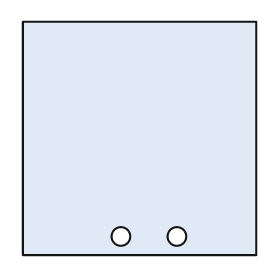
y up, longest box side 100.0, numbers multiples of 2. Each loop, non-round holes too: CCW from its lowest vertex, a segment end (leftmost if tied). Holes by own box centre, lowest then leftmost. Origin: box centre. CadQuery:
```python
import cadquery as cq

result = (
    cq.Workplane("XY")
    .moveTo(-50.0, -50.0)
    .lineTo(50.0, -50.0)
    .lineTo(50.0, 50.0)
    .lineTo(-50.0, 50.0)
    .close()
    .moveTo(-8.0, -42.0)
    .circle(4.0)
    .moveTo(16.0, -42.0)
    .circle(4.0)
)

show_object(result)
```